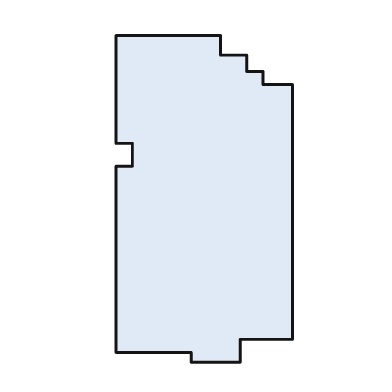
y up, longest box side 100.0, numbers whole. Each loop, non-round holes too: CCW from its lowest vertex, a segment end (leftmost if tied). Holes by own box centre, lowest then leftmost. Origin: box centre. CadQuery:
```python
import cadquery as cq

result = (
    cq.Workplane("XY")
    .moveTo(-4.0, -50.0)
    .lineTo(11.0, -50.0)
    .lineTo(11.0, -43.0)
    .lineTo(27.0, -43.0)
    .lineTo(27.0, 35.0)
    .lineTo(18.0, 35.0)
    .lineTo(18.0, 39.0)
    .lineTo(13.0, 39.0)
    .lineTo(13.0, 44.0)
    .lineTo(5.0, 44.0)
    .lineTo(5.0, 50.0)
    .lineTo(-27.0, 50.0)
    .lineTo(-27.0, 17.0)
    .lineTo(-22.0, 17.0)
    .lineTo(-22.0, 10.0)
    .lineTo(-27.0, 10.0)
    .lineTo(-27.0, -47.0)
    .lineTo(-4.0, -47.0)
    .close()
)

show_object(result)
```